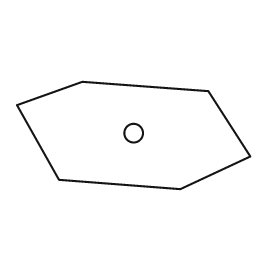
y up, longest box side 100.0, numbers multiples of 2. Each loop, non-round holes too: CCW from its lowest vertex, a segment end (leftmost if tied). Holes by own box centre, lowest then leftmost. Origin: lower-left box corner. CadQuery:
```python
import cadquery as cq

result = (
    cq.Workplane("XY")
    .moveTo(70.0, 0.0)
    .lineTo(100.0, 14.0)
    .lineTo(82.0, 42.0)
    .lineTo(28.0, 46.0)
    .lineTo(0.0, 36.0)
    .lineTo(18.0, 4.0)
    .close()
    .moveTo(50.0, 24.0)
    .circle(4.0)
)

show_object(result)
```